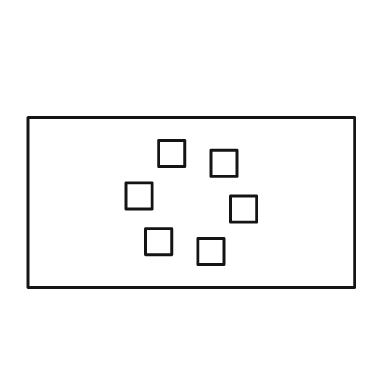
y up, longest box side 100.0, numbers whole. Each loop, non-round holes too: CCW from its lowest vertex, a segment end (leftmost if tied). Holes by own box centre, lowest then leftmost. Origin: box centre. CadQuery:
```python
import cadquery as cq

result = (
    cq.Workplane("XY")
    .moveTo(-50.0, -26.0)
    .lineTo(50.0, -26.0)
    .lineTo(50.0, 26.0)
    .lineTo(-50.0, 26.0)
    .close()
    .moveTo(2.0, -19.0)
    .lineTo(10.0, -19.0)
    .lineTo(10.0, -11.0)
    .lineTo(2.0, -11.0)
    .close()
    .moveTo(-14.0, -16.0)
    .lineTo(-6.0, -16.0)
    .lineTo(-6.0, -8.0)
    .lineTo(-14.0, -8.0)
    .close()
    .moveTo(12.0, -6.0)
    .lineTo(20.0, -6.0)
    .lineTo(20.0, 2.0)
    .lineTo(12.0, 2.0)
    .close()
    .moveTo(-20.0, -2.0)
    .lineTo(-12.0, -2.0)
    .lineTo(-12.0, 6.0)
    .lineTo(-20.0, 6.0)
    .close()
    .moveTo(6.0, 8.0)
    .lineTo(14.0, 8.0)
    .lineTo(14.0, 16.0)
    .lineTo(6.0, 16.0)
    .close()
    .moveTo(-10.0, 11.0)
    .lineTo(-2.0, 11.0)
    .lineTo(-2.0, 19.0)
    .lineTo(-10.0, 19.0)
    .close()
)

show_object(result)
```